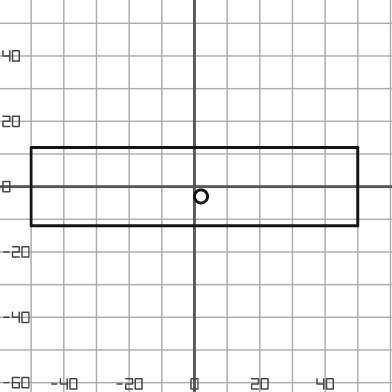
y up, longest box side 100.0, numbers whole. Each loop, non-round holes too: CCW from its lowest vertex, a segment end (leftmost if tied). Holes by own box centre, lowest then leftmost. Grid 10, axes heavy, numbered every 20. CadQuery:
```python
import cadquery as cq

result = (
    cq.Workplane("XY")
    .moveTo(-50.0, -12.0)
    .lineTo(50.0, -12.0)
    .lineTo(50.0, 12.0)
    .lineTo(-50.0, 12.0)
    .close()
    .moveTo(2.0, -3.0)
    .circle(2.0)
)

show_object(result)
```